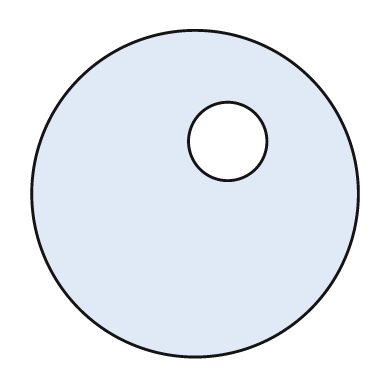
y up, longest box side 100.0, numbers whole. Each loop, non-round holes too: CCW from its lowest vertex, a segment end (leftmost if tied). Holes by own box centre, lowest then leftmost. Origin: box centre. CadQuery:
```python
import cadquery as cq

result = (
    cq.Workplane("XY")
    .moveTo(0.0, 0.0)
    .circle(50.0)
    .moveTo(10.0, 16.0)
    .circle(12.0)
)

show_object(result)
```